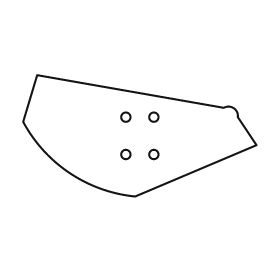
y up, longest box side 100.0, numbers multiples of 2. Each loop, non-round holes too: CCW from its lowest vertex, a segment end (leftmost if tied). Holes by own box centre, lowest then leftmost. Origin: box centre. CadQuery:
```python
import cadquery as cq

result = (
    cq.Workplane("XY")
    .moveTo(-2.0, -26.0)
    .lineTo(50.0, -4.0)
    .lineTo(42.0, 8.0)
    .threePointArc((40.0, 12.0), (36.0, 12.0))
    .lineTo(-44.0, 26.0)
    .lineTo(-50.0, 6.0)
    .threePointArc((-30.0, -16.0), (-2.0, -26.0))
    .close()
    .moveTo(-6.0, -8.0)
    .circle(2.0)
    .moveTo(6.0, -8.0)
    .circle(2.0)
    .moveTo(-6.0, 8.0)
    .circle(2.0)
    .moveTo(6.0, 8.0)
    .circle(2.0)
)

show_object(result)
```